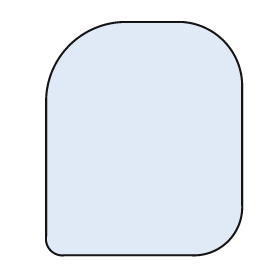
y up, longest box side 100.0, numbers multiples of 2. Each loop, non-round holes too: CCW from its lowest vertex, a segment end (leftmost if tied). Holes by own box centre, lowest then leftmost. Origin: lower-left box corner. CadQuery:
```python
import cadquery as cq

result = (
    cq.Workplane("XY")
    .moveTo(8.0, 0.0)
    .lineTo(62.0, 0.0)
    .threePointArc((78.0, 6.0), (84.0, 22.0))
    .lineTo(84.0, 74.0)
    .threePointArc((76.0, 92.0), (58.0, 100.0))
    .lineTo(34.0, 100.0)
    .threePointArc((10.0, 90.0), (0.0, 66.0))
    .lineTo(0.0, 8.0)
    .threePointArc((2.0, 2.0), (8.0, 0.0))
    .close()
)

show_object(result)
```